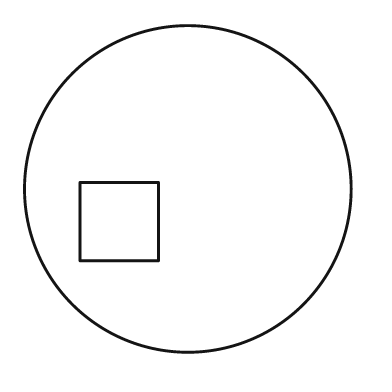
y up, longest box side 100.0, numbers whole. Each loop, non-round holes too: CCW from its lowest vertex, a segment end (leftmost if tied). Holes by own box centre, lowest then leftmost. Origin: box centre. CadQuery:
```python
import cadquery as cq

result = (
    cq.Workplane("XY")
    .moveTo(0.0, 0.0)
    .circle(50.0)
    .moveTo(-33.0, -22.0)
    .lineTo(-9.0, -22.0)
    .lineTo(-9.0, 2.0)
    .lineTo(-33.0, 2.0)
    .close()
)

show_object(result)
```